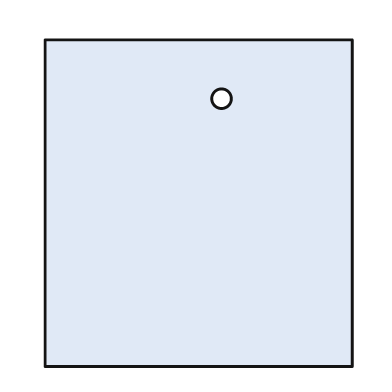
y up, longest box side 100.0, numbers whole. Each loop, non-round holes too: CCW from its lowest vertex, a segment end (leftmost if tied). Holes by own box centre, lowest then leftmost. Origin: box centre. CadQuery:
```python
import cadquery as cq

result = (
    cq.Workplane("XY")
    .moveTo(-47.0, -50.0)
    .lineTo(47.0, -50.0)
    .lineTo(47.0, 50.0)
    .lineTo(-47.0, 50.0)
    .close()
    .moveTo(7.0, 32.0)
    .circle(3.0)
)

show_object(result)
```